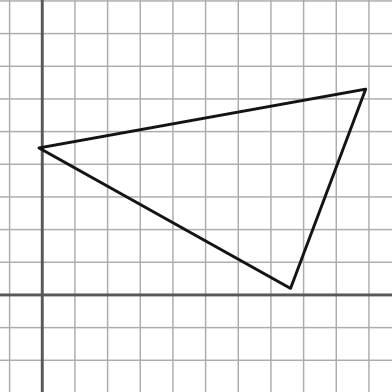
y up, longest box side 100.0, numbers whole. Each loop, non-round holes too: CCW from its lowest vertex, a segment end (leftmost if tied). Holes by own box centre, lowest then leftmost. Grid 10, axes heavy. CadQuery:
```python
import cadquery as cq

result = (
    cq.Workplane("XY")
    .moveTo(76.0, 2.0)
    .lineTo(99.0, 63.0)
    .lineTo(-1.0, 45.0)
    .close()
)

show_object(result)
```